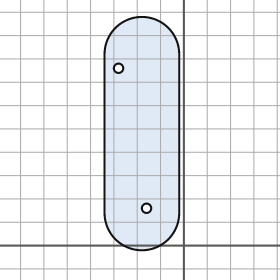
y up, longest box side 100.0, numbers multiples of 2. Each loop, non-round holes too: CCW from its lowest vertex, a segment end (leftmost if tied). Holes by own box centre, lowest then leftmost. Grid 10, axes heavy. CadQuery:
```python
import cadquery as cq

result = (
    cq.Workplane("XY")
    .moveTo(-34.0, 14.0)
    .threePointArc((-18.0, -2.0), (-2.0, 14.0))
    .lineTo(-2.0, 82.0)
    .threePointArc((-18.0, 98.0), (-34.0, 82.0))
    .close()
    .moveTo(-16.0, 16.0)
    .circle(2.0)
    .moveTo(-28.0, 76.0)
    .circle(2.0)
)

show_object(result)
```